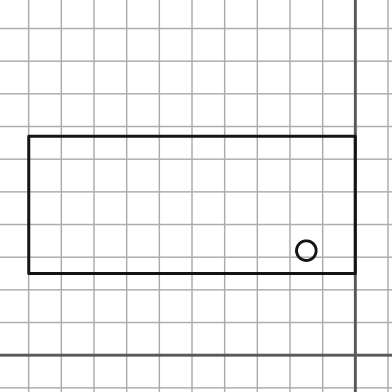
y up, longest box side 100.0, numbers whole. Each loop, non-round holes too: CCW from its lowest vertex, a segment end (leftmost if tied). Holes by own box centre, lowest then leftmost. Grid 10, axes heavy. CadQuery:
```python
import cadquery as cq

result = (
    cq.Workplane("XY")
    .moveTo(-100.0, 25.0)
    .lineTo(0.0, 25.0)
    .lineTo(0.0, 67.0)
    .lineTo(-100.0, 67.0)
    .close()
    .moveTo(-15.0, 32.0)
    .circle(3.0)
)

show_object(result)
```